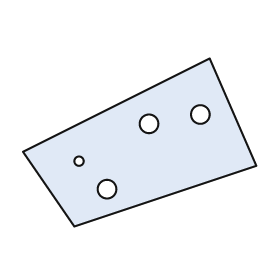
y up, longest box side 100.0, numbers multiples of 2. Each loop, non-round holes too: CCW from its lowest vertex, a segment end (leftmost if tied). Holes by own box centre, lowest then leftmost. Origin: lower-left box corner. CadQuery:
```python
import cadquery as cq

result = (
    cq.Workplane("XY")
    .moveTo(22.0, 0.0)
    .lineTo(100.0, 26.0)
    .lineTo(80.0, 72.0)
    .lineTo(0.0, 32.0)
    .close()
    .moveTo(36.0, 16.0)
    .circle(4.0)
    .moveTo(24.0, 28.0)
    .circle(2.0)
    .moveTo(54.0, 44.0)
    .circle(4.0)
    .moveTo(76.0, 48.0)
    .circle(4.0)
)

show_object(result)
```